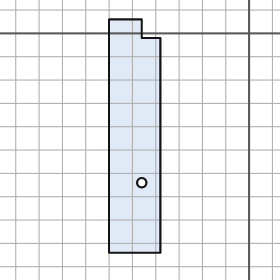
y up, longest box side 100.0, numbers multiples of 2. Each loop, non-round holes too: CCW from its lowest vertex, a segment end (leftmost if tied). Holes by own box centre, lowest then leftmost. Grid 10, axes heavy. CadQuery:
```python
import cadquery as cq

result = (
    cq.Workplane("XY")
    .moveTo(-60.0, -94.0)
    .lineTo(-38.0, -94.0)
    .lineTo(-38.0, -2.0)
    .lineTo(-46.0, -2.0)
    .lineTo(-46.0, 6.0)
    .lineTo(-60.0, 6.0)
    .close()
    .moveTo(-46.0, -64.0)
    .circle(2.0)
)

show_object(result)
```